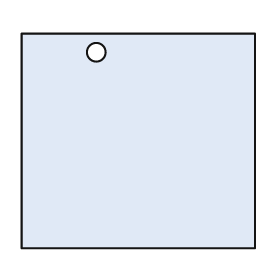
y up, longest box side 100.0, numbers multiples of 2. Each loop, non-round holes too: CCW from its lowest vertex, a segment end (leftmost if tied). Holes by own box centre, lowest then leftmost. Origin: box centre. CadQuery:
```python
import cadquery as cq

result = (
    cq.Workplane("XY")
    .moveTo(-50.0, -46.0)
    .lineTo(50.0, -46.0)
    .lineTo(50.0, 46.0)
    .lineTo(-50.0, 46.0)
    .close()
    .moveTo(-18.0, 38.0)
    .circle(4.0)
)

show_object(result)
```